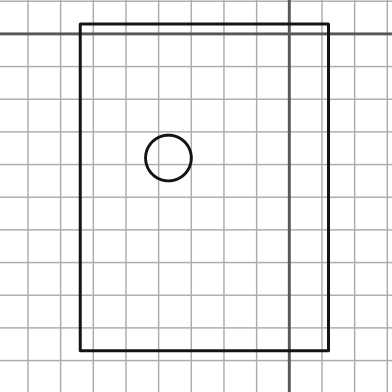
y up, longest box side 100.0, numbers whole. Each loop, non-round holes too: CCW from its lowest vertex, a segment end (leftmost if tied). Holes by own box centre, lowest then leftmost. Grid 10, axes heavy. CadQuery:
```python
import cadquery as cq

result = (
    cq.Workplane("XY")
    .moveTo(-64.0, -97.0)
    .lineTo(12.0, -97.0)
    .lineTo(12.0, 3.0)
    .lineTo(-64.0, 3.0)
    .close()
    .moveTo(-37.0, -38.0)
    .circle(7.0)
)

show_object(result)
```